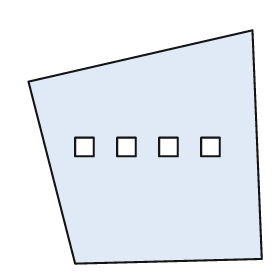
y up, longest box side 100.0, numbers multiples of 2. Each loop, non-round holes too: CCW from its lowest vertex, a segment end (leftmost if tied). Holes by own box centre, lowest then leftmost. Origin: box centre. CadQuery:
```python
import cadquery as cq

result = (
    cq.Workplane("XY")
    .moveTo(-30.0, -50.0)
    .lineTo(50.0, -48.0)
    .lineTo(46.0, 50.0)
    .lineTo(-50.0, 28.0)
    .close()
    .moveTo(-30.0, -4.0)
    .lineTo(-22.0, -4.0)
    .lineTo(-22.0, 4.0)
    .lineTo(-30.0, 4.0)
    .close()
    .moveTo(-12.0, -4.0)
    .lineTo(-4.0, -4.0)
    .lineTo(-4.0, 4.0)
    .lineTo(-12.0, 4.0)
    .close()
    .moveTo(6.0, -4.0)
    .lineTo(14.0, -4.0)
    .lineTo(14.0, 4.0)
    .lineTo(6.0, 4.0)
    .close()
    .moveTo(24.0, -4.0)
    .lineTo(32.0, -4.0)
    .lineTo(32.0, 4.0)
    .lineTo(24.0, 4.0)
    .close()
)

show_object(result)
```